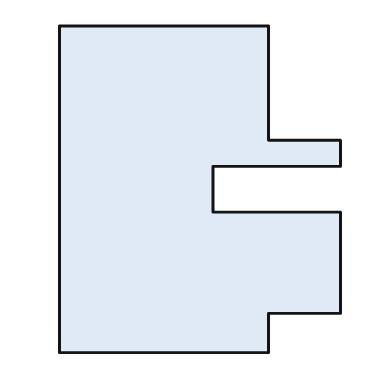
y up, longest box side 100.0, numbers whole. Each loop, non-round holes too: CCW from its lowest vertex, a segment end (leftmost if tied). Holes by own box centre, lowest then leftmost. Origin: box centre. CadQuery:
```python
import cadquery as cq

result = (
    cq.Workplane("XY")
    .moveTo(-43.0, -50.0)
    .lineTo(21.0, -50.0)
    .lineTo(21.0, -38.0)
    .lineTo(43.0, -38.0)
    .lineTo(43.0, -7.0)
    .lineTo(4.0, -7.0)
    .lineTo(4.0, 7.0)
    .lineTo(43.0, 7.0)
    .lineTo(43.0, 15.0)
    .lineTo(21.0, 15.0)
    .lineTo(21.0, 50.0)
    .lineTo(-43.0, 50.0)
    .close()
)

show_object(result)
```